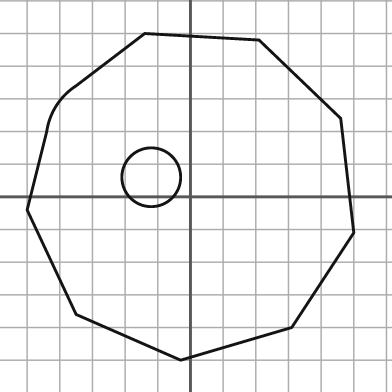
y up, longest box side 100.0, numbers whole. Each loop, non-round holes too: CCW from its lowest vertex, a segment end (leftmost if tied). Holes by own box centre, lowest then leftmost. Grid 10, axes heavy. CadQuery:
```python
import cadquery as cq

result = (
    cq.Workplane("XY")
    .moveTo(-3.0, -50.0)
    .lineTo(31.0, -40.0)
    .lineTo(50.0, -11.0)
    .lineTo(46.0, 24.0)
    .lineTo(21.0, 48.0)
    .lineTo(-14.0, 50.0)
    .lineTo(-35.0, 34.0)
    .threePointArc((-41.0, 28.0), (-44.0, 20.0))
    .lineTo(-50.0, -4.0)
    .lineTo(-35.0, -36.0)
    .close()
    .moveTo(-12.0, 6.0)
    .circle(9.0)
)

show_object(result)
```